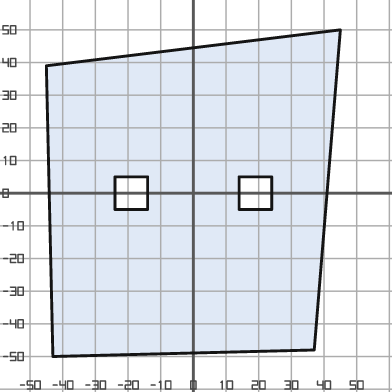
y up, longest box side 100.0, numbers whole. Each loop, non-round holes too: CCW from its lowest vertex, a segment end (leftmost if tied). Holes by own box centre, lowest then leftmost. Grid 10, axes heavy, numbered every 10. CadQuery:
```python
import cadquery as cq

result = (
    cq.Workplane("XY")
    .moveTo(-43.0, -50.0)
    .lineTo(37.0, -48.0)
    .lineTo(45.0, 50.0)
    .lineTo(-45.0, 39.0)
    .close()
    .moveTo(-24.0, -5.0)
    .lineTo(-14.0, -5.0)
    .lineTo(-14.0, 5.0)
    .lineTo(-24.0, 5.0)
    .close()
    .moveTo(14.0, -5.0)
    .lineTo(24.0, -5.0)
    .lineTo(24.0, 5.0)
    .lineTo(14.0, 5.0)
    .close()
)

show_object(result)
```